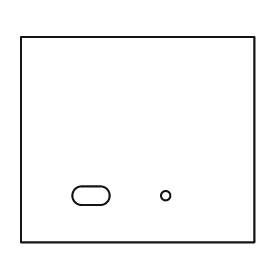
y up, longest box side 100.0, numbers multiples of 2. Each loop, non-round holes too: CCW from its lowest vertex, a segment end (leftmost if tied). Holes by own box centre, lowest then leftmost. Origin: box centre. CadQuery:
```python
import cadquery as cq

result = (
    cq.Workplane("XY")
    .moveTo(-50.0, -44.0)
    .lineTo(50.0, -44.0)
    .lineTo(50.0, 44.0)
    .lineTo(-50.0, 44.0)
    .close()
    .moveTo(-24.0, -28.0)
    .lineTo(-16.0, -28.0)
    .threePointArc((-12.0, -24.0), (-16.0, -20.0))
    .lineTo(-24.0, -20.0)
    .threePointArc((-28.0, -24.0), (-24.0, -28.0))
    .close()
    .moveTo(12.0, -24.0)
    .circle(2.0)
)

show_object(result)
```